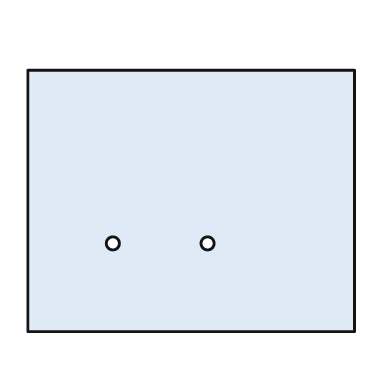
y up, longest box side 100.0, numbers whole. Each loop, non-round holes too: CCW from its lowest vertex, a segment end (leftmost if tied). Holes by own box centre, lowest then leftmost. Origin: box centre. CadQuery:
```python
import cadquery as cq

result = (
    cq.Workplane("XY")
    .moveTo(-50.0, -40.0)
    .lineTo(50.0, -40.0)
    .lineTo(50.0, 40.0)
    .lineTo(-50.0, 40.0)
    .close()
    .moveTo(-24.0, -13.0)
    .circle(2.0)
    .moveTo(5.0, -13.0)
    .circle(2.0)
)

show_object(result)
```